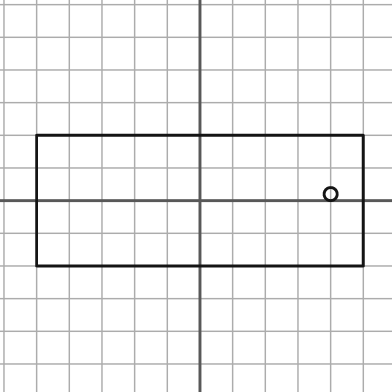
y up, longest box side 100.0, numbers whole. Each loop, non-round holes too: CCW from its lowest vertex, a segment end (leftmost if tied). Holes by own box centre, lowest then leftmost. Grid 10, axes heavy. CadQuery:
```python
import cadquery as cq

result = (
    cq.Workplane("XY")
    .moveTo(-50.0, -20.0)
    .lineTo(50.0, -20.0)
    .lineTo(50.0, 20.0)
    .lineTo(-50.0, 20.0)
    .close()
    .moveTo(40.0, 2.0)
    .circle(2.0)
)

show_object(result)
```